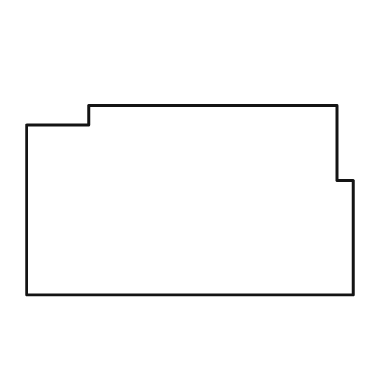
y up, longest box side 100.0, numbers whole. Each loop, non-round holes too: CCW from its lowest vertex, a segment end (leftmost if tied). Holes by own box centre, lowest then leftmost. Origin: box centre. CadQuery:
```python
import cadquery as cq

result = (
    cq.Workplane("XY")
    .moveTo(-50.0, -29.0)
    .lineTo(50.0, -29.0)
    .lineTo(50.0, 6.0)
    .lineTo(45.0, 6.0)
    .lineTo(45.0, 29.0)
    .lineTo(-31.0, 29.0)
    .lineTo(-31.0, 23.0)
    .lineTo(-50.0, 23.0)
    .close()
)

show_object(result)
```